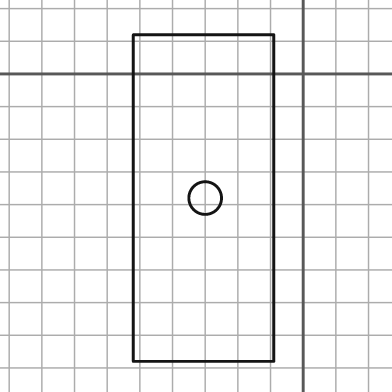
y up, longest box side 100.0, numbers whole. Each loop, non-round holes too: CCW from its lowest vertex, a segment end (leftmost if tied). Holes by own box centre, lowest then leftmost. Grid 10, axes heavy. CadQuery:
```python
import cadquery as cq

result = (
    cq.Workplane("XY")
    .moveTo(-52.0, -88.0)
    .lineTo(-9.0, -88.0)
    .lineTo(-9.0, 12.0)
    .lineTo(-52.0, 12.0)
    .close()
    .moveTo(-30.0, -38.0)
    .circle(5.0)
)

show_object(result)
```